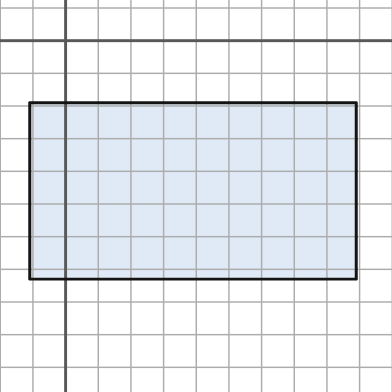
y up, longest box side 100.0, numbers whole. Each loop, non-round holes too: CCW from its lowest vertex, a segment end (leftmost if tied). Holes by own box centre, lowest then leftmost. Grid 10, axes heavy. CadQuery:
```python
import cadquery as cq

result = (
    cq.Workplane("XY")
    .moveTo(-11.0, -73.0)
    .lineTo(89.0, -73.0)
    .lineTo(89.0, -19.0)
    .lineTo(-11.0, -19.0)
    .close()
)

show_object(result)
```